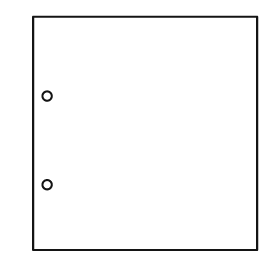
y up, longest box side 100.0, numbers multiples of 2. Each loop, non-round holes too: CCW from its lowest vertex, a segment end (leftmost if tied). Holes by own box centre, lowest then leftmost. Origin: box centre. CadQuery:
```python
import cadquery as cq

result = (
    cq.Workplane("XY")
    .moveTo(-48.0, -50.0)
    .lineTo(48.0, -50.0)
    .lineTo(48.0, 50.0)
    .lineTo(-48.0, 50.0)
    .close()
    .moveTo(-42.0, -22.0)
    .circle(2.0)
    .moveTo(-42.0, 16.0)
    .circle(2.0)
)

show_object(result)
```